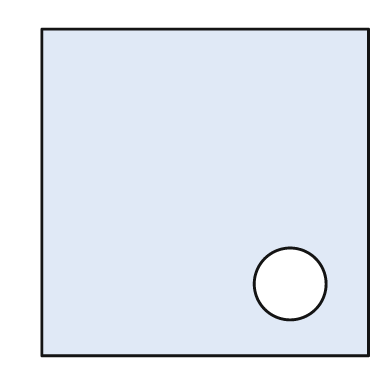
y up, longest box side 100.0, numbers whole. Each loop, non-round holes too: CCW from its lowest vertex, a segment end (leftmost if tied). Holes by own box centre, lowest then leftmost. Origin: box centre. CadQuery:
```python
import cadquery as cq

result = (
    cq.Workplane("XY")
    .moveTo(-50.0, -50.0)
    .lineTo(50.0, -50.0)
    .lineTo(50.0, 50.0)
    .lineTo(-50.0, 50.0)
    .close()
    .moveTo(26.0, -28.0)
    .circle(11.0)
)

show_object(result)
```